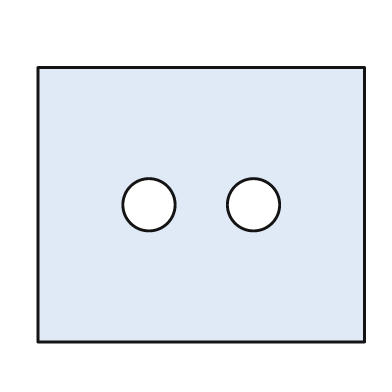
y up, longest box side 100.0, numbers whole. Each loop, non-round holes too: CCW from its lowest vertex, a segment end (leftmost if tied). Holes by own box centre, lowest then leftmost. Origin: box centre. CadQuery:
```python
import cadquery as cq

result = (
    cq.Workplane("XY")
    .moveTo(-50.0, -42.0)
    .lineTo(50.0, -42.0)
    .lineTo(50.0, 42.0)
    .lineTo(-50.0, 42.0)
    .close()
    .moveTo(-16.0, 0.0)
    .circle(8.0)
    .moveTo(16.0, 0.0)
    .circle(8.0)
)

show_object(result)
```